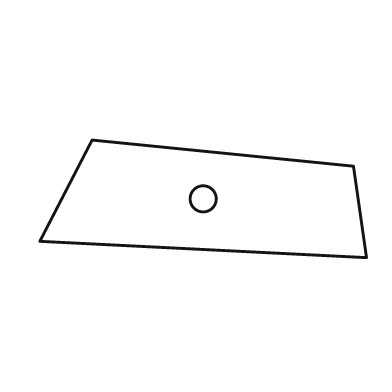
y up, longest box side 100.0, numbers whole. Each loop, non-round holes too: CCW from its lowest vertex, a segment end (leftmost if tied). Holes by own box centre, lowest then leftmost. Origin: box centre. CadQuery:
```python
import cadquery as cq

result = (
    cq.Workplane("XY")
    .moveTo(50.0, -18.0)
    .lineTo(46.0, 10.0)
    .lineTo(-34.0, 18.0)
    .lineTo(-50.0, -13.0)
    .close()
    .moveTo(0.0, 0.0)
    .circle(4.0)
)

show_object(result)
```